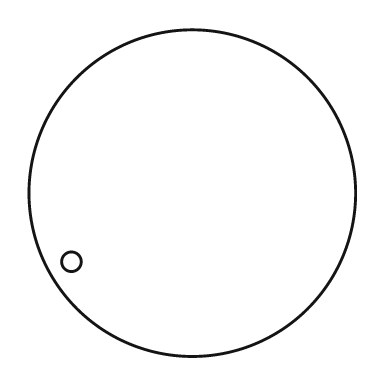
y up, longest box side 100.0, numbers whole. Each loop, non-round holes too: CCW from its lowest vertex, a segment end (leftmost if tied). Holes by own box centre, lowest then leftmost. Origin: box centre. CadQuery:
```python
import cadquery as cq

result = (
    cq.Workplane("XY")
    .moveTo(0.0, 0.0)
    .circle(50.0)
    .moveTo(-37.0, -21.0)
    .circle(3.0)
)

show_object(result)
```